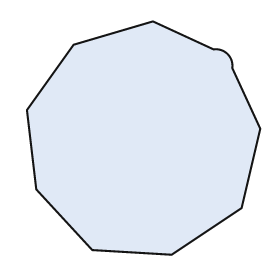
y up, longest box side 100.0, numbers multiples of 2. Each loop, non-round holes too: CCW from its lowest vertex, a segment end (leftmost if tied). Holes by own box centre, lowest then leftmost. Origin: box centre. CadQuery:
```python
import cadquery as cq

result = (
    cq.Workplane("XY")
    .moveTo(12.0, -50.0)
    .lineTo(42.0, -30.0)
    .lineTo(50.0, 4.0)
    .lineTo(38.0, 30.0)
    .threePointArc((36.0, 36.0), (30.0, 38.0))
    .lineTo(4.0, 50.0)
    .lineTo(-30.0, 40.0)
    .lineTo(-50.0, 12.0)
    .lineTo(-46.0, -22.0)
    .lineTo(-22.0, -48.0)
    .close()
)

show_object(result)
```